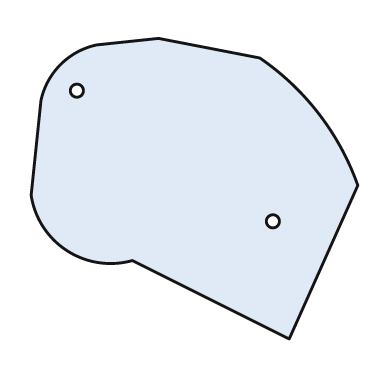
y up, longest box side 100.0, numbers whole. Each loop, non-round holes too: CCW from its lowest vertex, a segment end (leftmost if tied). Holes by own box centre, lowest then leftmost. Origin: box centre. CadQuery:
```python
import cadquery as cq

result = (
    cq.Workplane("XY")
    .moveTo(29.0, -46.0)
    .lineTo(50.0, 1.0)
    .threePointArc((38.0, 23.0), (20.0, 40.0))
    .lineTo(-11.0, 46.0)
    .lineTo(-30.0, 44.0)
    .threePointArc((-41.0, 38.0), (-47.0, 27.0))
    .lineTo(-50.0, -2.0)
    .threePointArc((-39.0, -19.0), (-19.0, -22.0))
    .close()
    .moveTo(24.0, -10.0)
    .circle(2.0)
    .moveTo(-36.0, 30.0)
    .circle(2.0)
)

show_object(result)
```